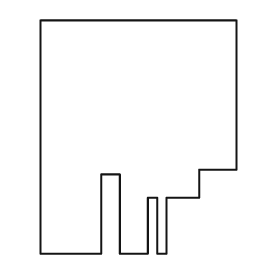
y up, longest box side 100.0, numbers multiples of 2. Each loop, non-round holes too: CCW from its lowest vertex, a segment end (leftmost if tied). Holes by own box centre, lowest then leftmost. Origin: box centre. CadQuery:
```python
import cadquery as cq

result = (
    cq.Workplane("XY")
    .moveTo(-42.0, -50.0)
    .lineTo(-16.0, -50.0)
    .lineTo(-16.0, -16.0)
    .lineTo(-8.0, -16.0)
    .lineTo(-8.0, -50.0)
    .lineTo(4.0, -50.0)
    .lineTo(4.0, -26.0)
    .lineTo(8.0, -26.0)
    .lineTo(8.0, -50.0)
    .lineTo(12.0, -50.0)
    .lineTo(12.0, -26.0)
    .lineTo(26.0, -26.0)
    .lineTo(26.0, -14.0)
    .lineTo(42.0, -14.0)
    .lineTo(42.0, 50.0)
    .lineTo(-42.0, 50.0)
    .close()
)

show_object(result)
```